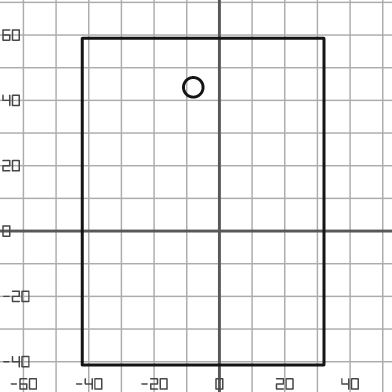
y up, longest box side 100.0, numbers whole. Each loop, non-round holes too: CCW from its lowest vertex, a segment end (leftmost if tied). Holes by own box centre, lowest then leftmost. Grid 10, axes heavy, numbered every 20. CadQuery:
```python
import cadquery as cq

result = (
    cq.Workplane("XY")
    .moveTo(-42.0, -41.0)
    .lineTo(32.0, -41.0)
    .lineTo(32.0, 59.0)
    .lineTo(-42.0, 59.0)
    .close()
    .moveTo(-8.0, 44.0)
    .circle(3.0)
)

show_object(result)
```